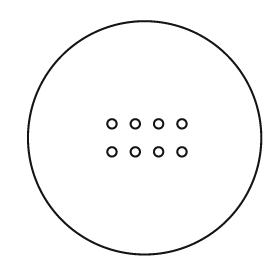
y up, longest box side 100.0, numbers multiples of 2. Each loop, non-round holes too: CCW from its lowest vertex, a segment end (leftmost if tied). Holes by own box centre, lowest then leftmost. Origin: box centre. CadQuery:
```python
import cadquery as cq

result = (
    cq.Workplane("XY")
    .moveTo(0.0, 0.0)
    .circle(50.0)
    .moveTo(-14.0, -6.0)
    .circle(2.0)
    .moveTo(-4.0, -6.0)
    .circle(2.0)
    .moveTo(6.0, -6.0)
    .circle(2.0)
    .moveTo(16.0, -6.0)
    .circle(2.0)
    .moveTo(-14.0, 6.0)
    .circle(2.0)
    .moveTo(-4.0, 6.0)
    .circle(2.0)
    .moveTo(6.0, 6.0)
    .circle(2.0)
    .moveTo(16.0, 6.0)
    .circle(2.0)
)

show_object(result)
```